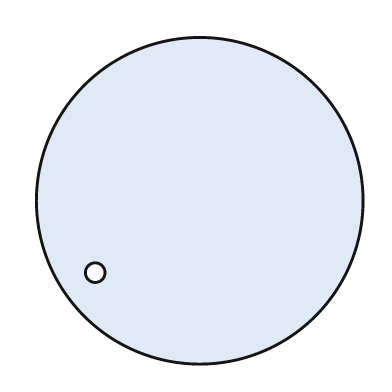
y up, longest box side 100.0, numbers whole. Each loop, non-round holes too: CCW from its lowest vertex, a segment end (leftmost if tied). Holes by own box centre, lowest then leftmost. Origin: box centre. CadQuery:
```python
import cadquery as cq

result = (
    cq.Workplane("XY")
    .moveTo(0.0, 0.0)
    .circle(50.0)
    .moveTo(-32.0, -22.0)
    .circle(3.0)
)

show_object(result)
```